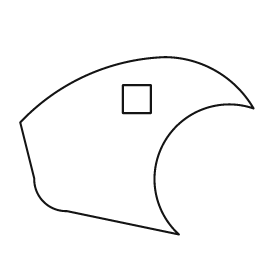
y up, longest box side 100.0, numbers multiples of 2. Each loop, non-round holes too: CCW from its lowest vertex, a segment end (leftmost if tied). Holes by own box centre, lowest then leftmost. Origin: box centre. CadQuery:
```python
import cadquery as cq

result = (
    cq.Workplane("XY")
    .moveTo(18.0, -38.0)
    .threePointArc((12.0, 2.0), (50.0, 16.0))
    .threePointArc((34.0, 32.0), (12.0, 38.0))
    .threePointArc((-22.0, 30.0), (-50.0, 10.0))
    .lineTo(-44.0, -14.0)
    .threePointArc((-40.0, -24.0), (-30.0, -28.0))
    .close()
    .moveTo(-6.0, 14.0)
    .lineTo(6.0, 14.0)
    .lineTo(6.0, 26.0)
    .lineTo(-6.0, 26.0)
    .close()
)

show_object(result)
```